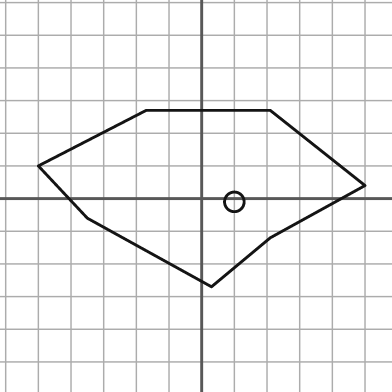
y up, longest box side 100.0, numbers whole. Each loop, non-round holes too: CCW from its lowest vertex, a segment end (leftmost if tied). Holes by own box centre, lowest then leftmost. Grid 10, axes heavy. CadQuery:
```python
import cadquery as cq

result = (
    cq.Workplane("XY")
    .moveTo(3.0, -27.0)
    .lineTo(21.0, -12.0)
    .lineTo(50.0, 4.0)
    .lineTo(21.0, 27.0)
    .lineTo(-17.0, 27.0)
    .lineTo(-50.0, 10.0)
    .lineTo(-35.0, -6.0)
    .close()
    .moveTo(10.0, -1.0)
    .circle(3.0)
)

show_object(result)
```